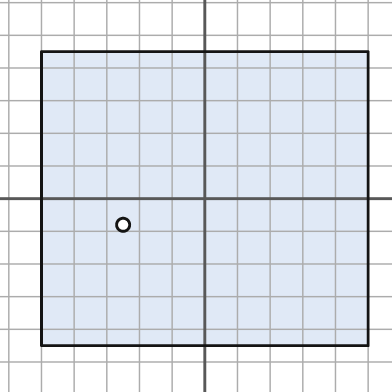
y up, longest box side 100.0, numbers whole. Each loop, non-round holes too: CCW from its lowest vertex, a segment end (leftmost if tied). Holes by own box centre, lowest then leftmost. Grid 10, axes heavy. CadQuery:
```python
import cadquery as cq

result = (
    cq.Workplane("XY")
    .moveTo(-50.0, -45.0)
    .lineTo(50.0, -45.0)
    .lineTo(50.0, 45.0)
    .lineTo(-50.0, 45.0)
    .close()
    .moveTo(-25.0, -8.0)
    .circle(2.0)
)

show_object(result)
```